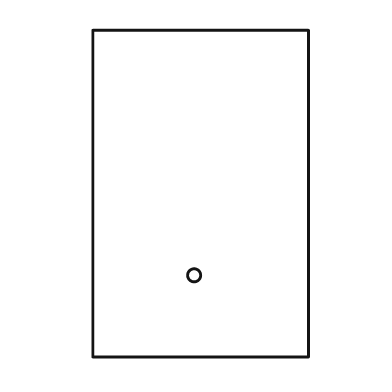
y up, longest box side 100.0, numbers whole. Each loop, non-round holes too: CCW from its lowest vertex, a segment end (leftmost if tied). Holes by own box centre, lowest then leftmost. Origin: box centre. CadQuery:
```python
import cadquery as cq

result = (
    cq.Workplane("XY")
    .moveTo(-33.0, -50.0)
    .lineTo(33.0, -50.0)
    .lineTo(33.0, 50.0)
    .lineTo(-33.0, 50.0)
    .close()
    .moveTo(-2.0, -25.0)
    .circle(2.0)
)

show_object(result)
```